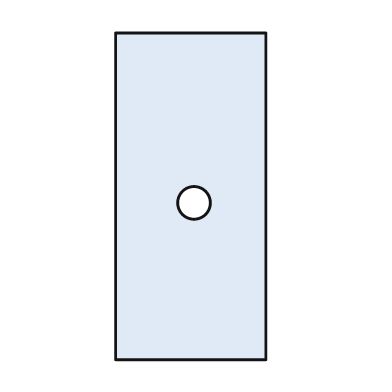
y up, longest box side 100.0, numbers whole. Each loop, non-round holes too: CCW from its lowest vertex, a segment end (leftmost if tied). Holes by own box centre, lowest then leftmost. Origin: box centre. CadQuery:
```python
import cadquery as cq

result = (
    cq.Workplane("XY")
    .moveTo(-23.0, -50.0)
    .lineTo(23.0, -50.0)
    .lineTo(23.0, 50.0)
    .lineTo(-23.0, 50.0)
    .close()
    .moveTo(1.0, -2.0)
    .circle(5.0)
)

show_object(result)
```